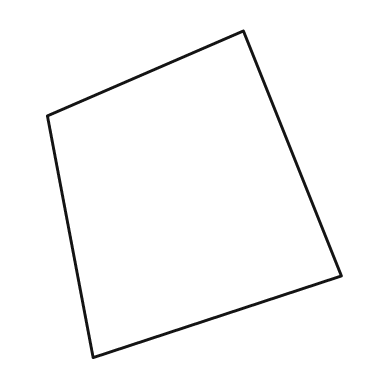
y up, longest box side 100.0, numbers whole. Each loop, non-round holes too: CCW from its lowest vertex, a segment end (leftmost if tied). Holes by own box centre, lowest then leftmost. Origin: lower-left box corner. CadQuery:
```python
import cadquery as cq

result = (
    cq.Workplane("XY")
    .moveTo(14.0, 0.0)
    .lineTo(90.0, 25.0)
    .lineTo(60.0, 100.0)
    .lineTo(0.0, 74.0)
    .close()
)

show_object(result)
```